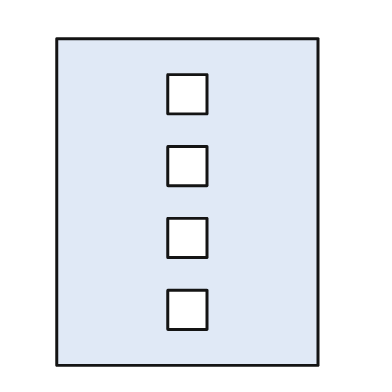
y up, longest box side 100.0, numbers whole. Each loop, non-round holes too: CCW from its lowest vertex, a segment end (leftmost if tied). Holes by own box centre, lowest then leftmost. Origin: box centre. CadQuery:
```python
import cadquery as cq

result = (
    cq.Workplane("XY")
    .moveTo(-40.0, -50.0)
    .lineTo(40.0, -50.0)
    .lineTo(40.0, 50.0)
    .lineTo(-40.0, 50.0)
    .close()
    .moveTo(-6.0, -39.0)
    .lineTo(6.0, -39.0)
    .lineTo(6.0, -27.0)
    .lineTo(-6.0, -27.0)
    .close()
    .moveTo(-6.0, -17.0)
    .lineTo(6.0, -17.0)
    .lineTo(6.0, -5.0)
    .lineTo(-6.0, -5.0)
    .close()
    .moveTo(-6.0, 5.0)
    .lineTo(6.0, 5.0)
    .lineTo(6.0, 17.0)
    .lineTo(-6.0, 17.0)
    .close()
    .moveTo(-6.0, 27.0)
    .lineTo(6.0, 27.0)
    .lineTo(6.0, 39.0)
    .lineTo(-6.0, 39.0)
    .close()
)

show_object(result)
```